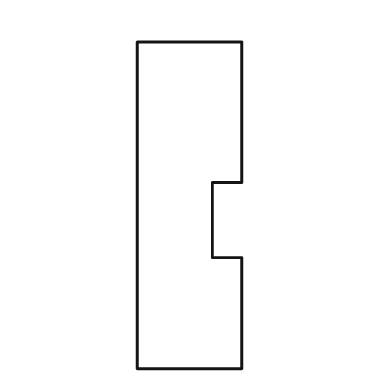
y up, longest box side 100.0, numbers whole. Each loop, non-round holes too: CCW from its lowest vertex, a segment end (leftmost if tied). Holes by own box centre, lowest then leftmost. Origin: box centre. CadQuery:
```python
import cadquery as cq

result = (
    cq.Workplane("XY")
    .moveTo(-16.0, -50.0)
    .lineTo(16.0, -50.0)
    .lineTo(16.0, -16.0)
    .lineTo(7.0, -16.0)
    .lineTo(7.0, 7.0)
    .lineTo(16.0, 7.0)
    .lineTo(16.0, 50.0)
    .lineTo(-16.0, 50.0)
    .close()
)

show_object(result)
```